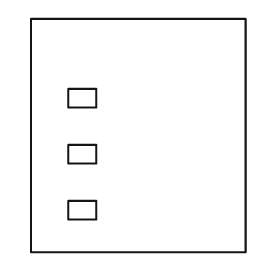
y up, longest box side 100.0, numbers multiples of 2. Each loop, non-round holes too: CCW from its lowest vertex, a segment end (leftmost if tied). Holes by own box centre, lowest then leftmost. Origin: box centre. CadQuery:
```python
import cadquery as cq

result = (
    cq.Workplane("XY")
    .moveTo(-46.0, -50.0)
    .lineTo(46.0, -50.0)
    .lineTo(46.0, 50.0)
    .lineTo(-46.0, 50.0)
    .close()
    .moveTo(-30.0, -36.0)
    .lineTo(-18.0, -36.0)
    .lineTo(-18.0, -28.0)
    .lineTo(-30.0, -28.0)
    .close()
    .moveTo(-30.0, -12.0)
    .lineTo(-18.0, -12.0)
    .lineTo(-18.0, -4.0)
    .lineTo(-30.0, -4.0)
    .close()
    .moveTo(-30.0, 12.0)
    .lineTo(-18.0, 12.0)
    .lineTo(-18.0, 20.0)
    .lineTo(-30.0, 20.0)
    .close()
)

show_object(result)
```